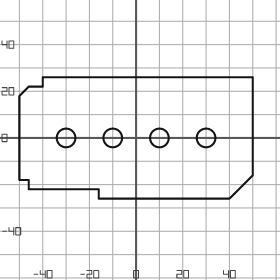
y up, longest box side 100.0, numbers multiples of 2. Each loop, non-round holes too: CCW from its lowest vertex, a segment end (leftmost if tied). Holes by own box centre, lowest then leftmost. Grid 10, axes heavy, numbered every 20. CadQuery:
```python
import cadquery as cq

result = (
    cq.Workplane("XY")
    .moveTo(-16.0, -26.0)
    .lineTo(40.0, -26.0)
    .lineTo(50.0, -16.0)
    .lineTo(50.0, 26.0)
    .lineTo(-40.0, 26.0)
    .lineTo(-40.0, 22.0)
    .lineTo(-46.0, 22.0)
    .lineTo(-50.0, 18.0)
    .lineTo(-50.0, -18.0)
    .lineTo(-46.0, -18.0)
    .lineTo(-46.0, -22.0)
    .lineTo(-16.0, -22.0)
    .close()
    .moveTo(-30.0, 0.0)
    .circle(4.0)
    .moveTo(-10.0, 0.0)
    .circle(4.0)
    .moveTo(10.0, 0.0)
    .circle(4.0)
    .moveTo(30.0, 0.0)
    .circle(4.0)
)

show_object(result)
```